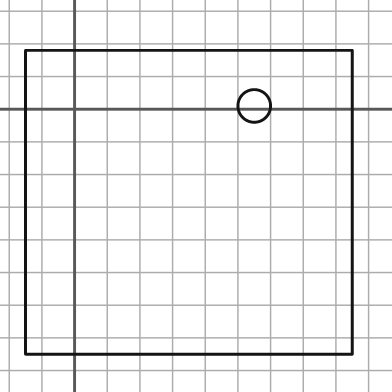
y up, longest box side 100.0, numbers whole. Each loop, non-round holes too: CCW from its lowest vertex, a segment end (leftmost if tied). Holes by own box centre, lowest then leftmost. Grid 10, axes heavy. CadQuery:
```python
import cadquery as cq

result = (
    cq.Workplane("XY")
    .moveTo(-15.0, -75.0)
    .lineTo(85.0, -75.0)
    .lineTo(85.0, 18.0)
    .lineTo(-15.0, 18.0)
    .close()
    .moveTo(55.0, 1.0)
    .circle(5.0)
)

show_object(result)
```